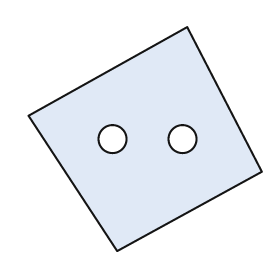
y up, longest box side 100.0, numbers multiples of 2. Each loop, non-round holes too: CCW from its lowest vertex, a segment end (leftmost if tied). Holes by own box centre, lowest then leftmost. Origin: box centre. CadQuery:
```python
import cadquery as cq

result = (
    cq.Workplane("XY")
    .moveTo(-12.0, -48.0)
    .lineTo(50.0, -14.0)
    .lineTo(18.0, 48.0)
    .lineTo(-50.0, 10.0)
    .close()
    .moveTo(-14.0, 0.0)
    .circle(6.0)
    .moveTo(16.0, 0.0)
    .circle(6.0)
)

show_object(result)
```